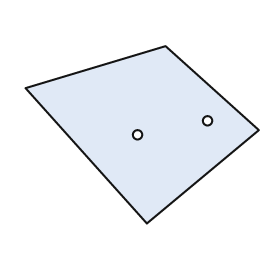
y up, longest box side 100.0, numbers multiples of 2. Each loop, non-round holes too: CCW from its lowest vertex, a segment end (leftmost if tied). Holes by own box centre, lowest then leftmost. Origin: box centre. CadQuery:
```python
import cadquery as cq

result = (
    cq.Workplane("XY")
    .moveTo(2.0, -38.0)
    .lineTo(50.0, 2.0)
    .lineTo(10.0, 38.0)
    .lineTo(-50.0, 20.0)
    .close()
    .moveTo(-2.0, 0.0)
    .circle(2.0)
    .moveTo(28.0, 6.0)
    .circle(2.0)
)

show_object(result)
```